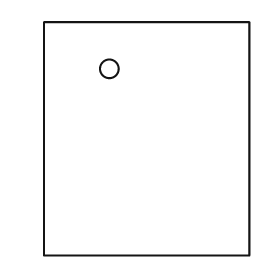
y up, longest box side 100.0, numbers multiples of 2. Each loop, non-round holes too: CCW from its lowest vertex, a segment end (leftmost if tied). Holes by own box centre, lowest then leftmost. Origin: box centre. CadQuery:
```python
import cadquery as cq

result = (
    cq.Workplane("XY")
    .moveTo(-44.0, -50.0)
    .lineTo(44.0, -50.0)
    .lineTo(44.0, 50.0)
    .lineTo(-44.0, 50.0)
    .close()
    .moveTo(-16.0, 30.0)
    .circle(4.0)
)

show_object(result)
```